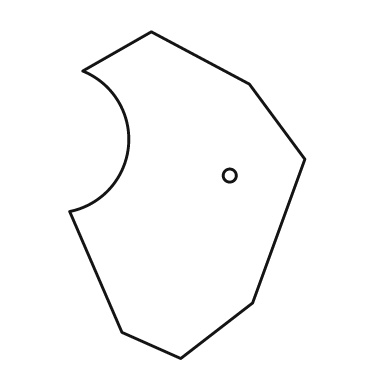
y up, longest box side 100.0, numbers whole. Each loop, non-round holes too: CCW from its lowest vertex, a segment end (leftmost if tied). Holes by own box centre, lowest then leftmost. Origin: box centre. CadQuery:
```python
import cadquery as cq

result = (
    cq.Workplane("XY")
    .moveTo(-2.0, -50.0)
    .lineTo(20.0, -33.0)
    .lineTo(36.0, 11.0)
    .lineTo(19.0, 34.0)
    .lineTo(-11.0, 50.0)
    .lineTo(-32.0, 38.0)
    .threePointArc((-18.0, 15.0), (-36.0, -5.0))
    .lineTo(-20.0, -42.0)
    .close()
    .moveTo(13.0, 6.0)
    .circle(2.0)
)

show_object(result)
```